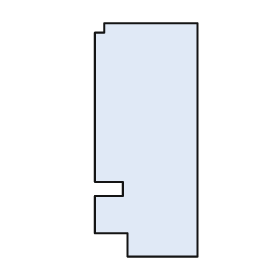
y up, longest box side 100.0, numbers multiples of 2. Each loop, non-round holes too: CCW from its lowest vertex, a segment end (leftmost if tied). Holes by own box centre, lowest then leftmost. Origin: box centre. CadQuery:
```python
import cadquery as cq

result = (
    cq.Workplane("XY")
    .moveTo(-8.0, -50.0)
    .lineTo(22.0, -50.0)
    .lineTo(22.0, 50.0)
    .lineTo(-18.0, 50.0)
    .lineTo(-18.0, 46.0)
    .lineTo(-22.0, 46.0)
    .lineTo(-22.0, -18.0)
    .lineTo(-10.0, -18.0)
    .lineTo(-10.0, -24.0)
    .lineTo(-22.0, -24.0)
    .lineTo(-22.0, -40.0)
    .lineTo(-8.0, -40.0)
    .close()
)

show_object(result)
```